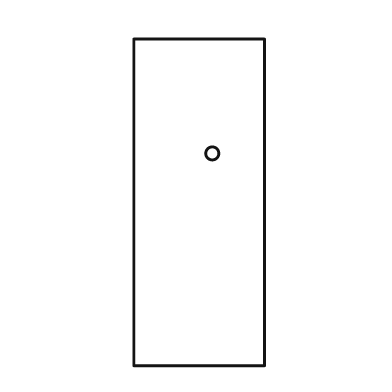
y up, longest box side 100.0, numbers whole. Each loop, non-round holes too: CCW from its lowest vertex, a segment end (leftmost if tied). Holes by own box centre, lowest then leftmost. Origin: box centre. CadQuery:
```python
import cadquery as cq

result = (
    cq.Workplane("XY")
    .moveTo(-20.0, -50.0)
    .lineTo(20.0, -50.0)
    .lineTo(20.0, 50.0)
    .lineTo(-20.0, 50.0)
    .close()
    .moveTo(4.0, 15.0)
    .circle(2.0)
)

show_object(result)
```